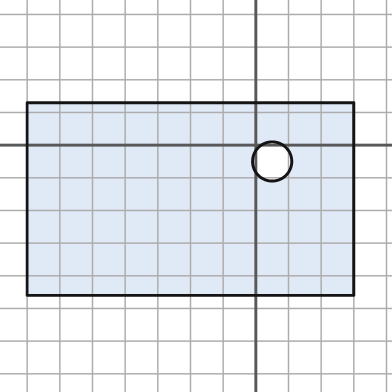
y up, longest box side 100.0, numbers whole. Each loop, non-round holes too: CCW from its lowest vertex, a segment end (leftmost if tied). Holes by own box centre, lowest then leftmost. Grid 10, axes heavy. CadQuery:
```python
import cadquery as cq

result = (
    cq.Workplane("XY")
    .moveTo(-70.0, -46.0)
    .lineTo(30.0, -46.0)
    .lineTo(30.0, 13.0)
    .lineTo(-70.0, 13.0)
    .close()
    .moveTo(5.0, -5.0)
    .circle(6.0)
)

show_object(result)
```